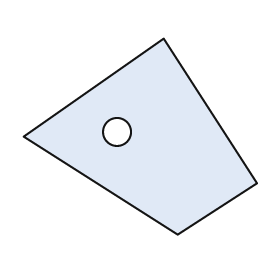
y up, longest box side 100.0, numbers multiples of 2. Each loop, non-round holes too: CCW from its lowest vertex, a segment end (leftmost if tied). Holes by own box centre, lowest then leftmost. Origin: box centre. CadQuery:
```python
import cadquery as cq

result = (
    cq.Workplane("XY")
    .moveTo(16.0, -42.0)
    .lineTo(50.0, -20.0)
    .lineTo(10.0, 42.0)
    .lineTo(-50.0, 0.0)
    .close()
    .moveTo(-10.0, 2.0)
    .circle(6.0)
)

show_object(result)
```